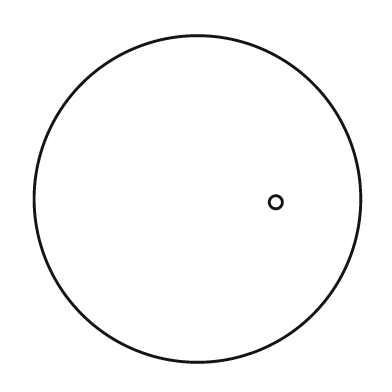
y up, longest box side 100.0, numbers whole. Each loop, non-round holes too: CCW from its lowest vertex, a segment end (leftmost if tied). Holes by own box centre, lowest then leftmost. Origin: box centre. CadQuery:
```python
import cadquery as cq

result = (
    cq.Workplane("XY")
    .moveTo(0.0, 0.0)
    .circle(50.0)
    .moveTo(24.0, -1.0)
    .circle(2.0)
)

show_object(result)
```